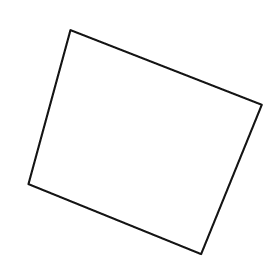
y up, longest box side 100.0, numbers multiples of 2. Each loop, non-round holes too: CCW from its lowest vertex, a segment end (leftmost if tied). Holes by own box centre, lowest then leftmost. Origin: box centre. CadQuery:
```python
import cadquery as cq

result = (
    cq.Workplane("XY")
    .moveTo(24.0, -48.0)
    .lineTo(50.0, 16.0)
    .lineTo(-32.0, 48.0)
    .lineTo(-50.0, -18.0)
    .close()
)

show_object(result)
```